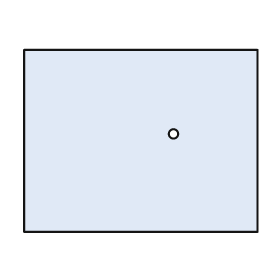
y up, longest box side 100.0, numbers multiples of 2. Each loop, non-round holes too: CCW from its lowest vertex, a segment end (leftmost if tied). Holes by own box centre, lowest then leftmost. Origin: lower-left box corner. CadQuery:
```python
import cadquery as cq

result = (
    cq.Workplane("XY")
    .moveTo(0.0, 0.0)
    .lineTo(100.0, 0.0)
    .lineTo(100.0, 78.0)
    .lineTo(0.0, 78.0)
    .close()
    .moveTo(64.0, 42.0)
    .circle(2.0)
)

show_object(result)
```